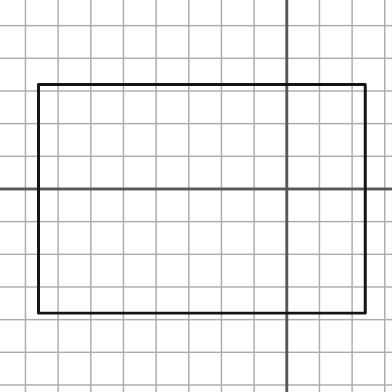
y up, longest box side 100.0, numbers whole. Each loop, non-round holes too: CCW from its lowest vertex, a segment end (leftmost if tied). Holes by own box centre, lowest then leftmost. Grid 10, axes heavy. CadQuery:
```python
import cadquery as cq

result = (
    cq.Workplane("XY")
    .moveTo(-76.0, -38.0)
    .lineTo(24.0, -38.0)
    .lineTo(24.0, 32.0)
    .lineTo(-76.0, 32.0)
    .close()
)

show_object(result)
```